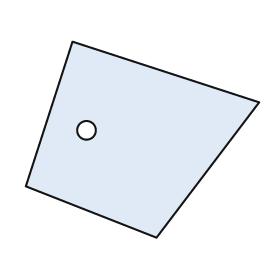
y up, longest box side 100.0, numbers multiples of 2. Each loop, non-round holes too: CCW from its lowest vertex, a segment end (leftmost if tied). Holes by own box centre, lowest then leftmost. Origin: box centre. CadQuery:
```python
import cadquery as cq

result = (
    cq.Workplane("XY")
    .moveTo(6.0, -42.0)
    .lineTo(50.0, 16.0)
    .lineTo(-30.0, 42.0)
    .lineTo(-50.0, -20.0)
    .close()
    .moveTo(-24.0, 4.0)
    .circle(4.0)
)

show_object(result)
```